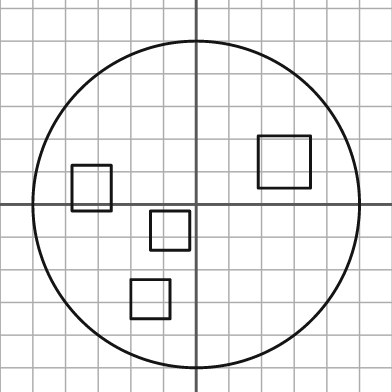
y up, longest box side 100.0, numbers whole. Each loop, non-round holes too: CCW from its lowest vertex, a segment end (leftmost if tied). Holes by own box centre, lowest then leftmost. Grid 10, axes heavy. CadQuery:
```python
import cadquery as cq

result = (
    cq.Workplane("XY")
    .moveTo(0.0, 0.0)
    .circle(50.0)
    .moveTo(-20.0, -35.0)
    .lineTo(-8.0, -35.0)
    .lineTo(-8.0, -23.0)
    .lineTo(-20.0, -23.0)
    .close()
    .moveTo(-14.0, -14.0)
    .lineTo(-2.0, -14.0)
    .lineTo(-2.0, -2.0)
    .lineTo(-14.0, -2.0)
    .close()
    .moveTo(-38.0, -2.0)
    .lineTo(-26.0, -2.0)
    .lineTo(-26.0, 12.0)
    .lineTo(-38.0, 12.0)
    .close()
    .moveTo(19.0, 5.0)
    .lineTo(35.0, 5.0)
    .lineTo(35.0, 21.0)
    .lineTo(19.0, 21.0)
    .close()
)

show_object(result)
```